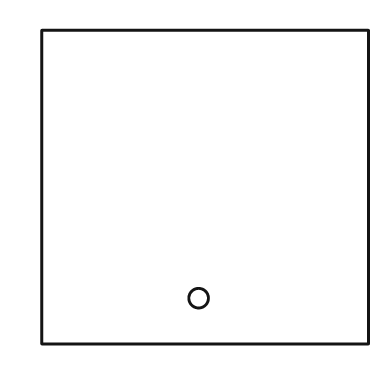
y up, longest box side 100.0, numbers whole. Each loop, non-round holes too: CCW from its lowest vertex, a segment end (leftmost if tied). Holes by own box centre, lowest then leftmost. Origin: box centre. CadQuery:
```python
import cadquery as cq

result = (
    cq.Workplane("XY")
    .moveTo(-50.0, -48.0)
    .lineTo(50.0, -48.0)
    .lineTo(50.0, 48.0)
    .lineTo(-50.0, 48.0)
    .close()
    .moveTo(-2.0, -34.0)
    .circle(3.0)
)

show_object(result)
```